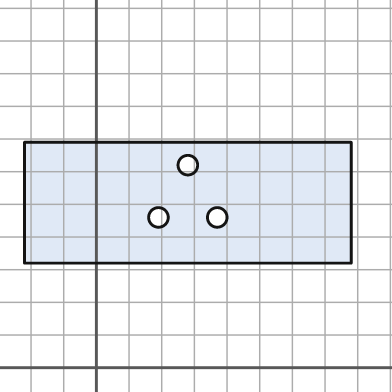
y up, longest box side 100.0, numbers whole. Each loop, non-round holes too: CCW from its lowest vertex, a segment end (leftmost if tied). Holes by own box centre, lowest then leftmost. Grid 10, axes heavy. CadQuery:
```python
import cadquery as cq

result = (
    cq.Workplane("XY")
    .moveTo(-22.0, 32.0)
    .lineTo(78.0, 32.0)
    .lineTo(78.0, 69.0)
    .lineTo(-22.0, 69.0)
    .close()
    .moveTo(19.0, 46.0)
    .circle(3.0)
    .moveTo(37.0, 46.0)
    .circle(3.0)
    .moveTo(28.0, 62.0)
    .circle(3.0)
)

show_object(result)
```